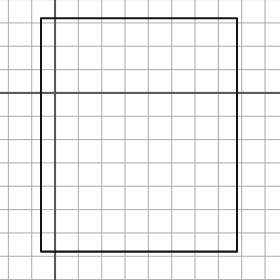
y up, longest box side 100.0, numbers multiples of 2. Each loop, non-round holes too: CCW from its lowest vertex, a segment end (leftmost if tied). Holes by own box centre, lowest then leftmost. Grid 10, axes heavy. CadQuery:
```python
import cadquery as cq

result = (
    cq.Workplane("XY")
    .moveTo(-6.0, -68.0)
    .lineTo(78.0, -68.0)
    .lineTo(78.0, 32.0)
    .lineTo(-6.0, 32.0)
    .close()
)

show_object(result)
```